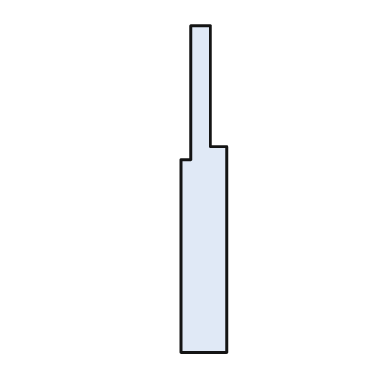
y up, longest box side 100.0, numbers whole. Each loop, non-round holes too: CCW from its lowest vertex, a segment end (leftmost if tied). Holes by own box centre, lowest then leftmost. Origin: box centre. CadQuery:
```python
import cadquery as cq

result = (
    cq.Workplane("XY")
    .moveTo(-7.0, -50.0)
    .lineTo(7.0, -50.0)
    .lineTo(7.0, 13.0)
    .lineTo(2.0, 13.0)
    .lineTo(2.0, 50.0)
    .lineTo(-4.0, 50.0)
    .lineTo(-4.0, 9.0)
    .lineTo(-7.0, 9.0)
    .close()
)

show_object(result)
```